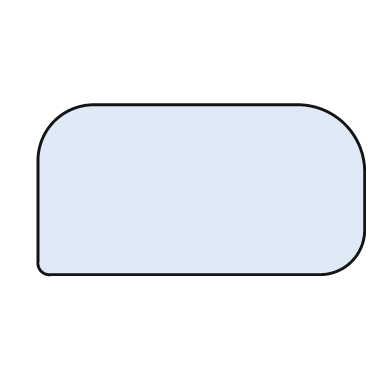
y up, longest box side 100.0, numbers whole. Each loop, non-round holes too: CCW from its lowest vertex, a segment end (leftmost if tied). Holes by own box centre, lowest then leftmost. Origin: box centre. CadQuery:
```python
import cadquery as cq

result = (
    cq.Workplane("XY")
    .moveTo(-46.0, -26.0)
    .lineTo(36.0, -26.0)
    .threePointArc((46.0, -22.0), (50.0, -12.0))
    .lineTo(50.0, 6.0)
    .threePointArc((44.0, 20.0), (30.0, 26.0))
    .lineTo(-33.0, 26.0)
    .threePointArc((-45.0, 21.0), (-50.0, 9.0))
    .lineTo(-50.0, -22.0)
    .threePointArc((-49.0, -25.0), (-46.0, -26.0))
    .close()
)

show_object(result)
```